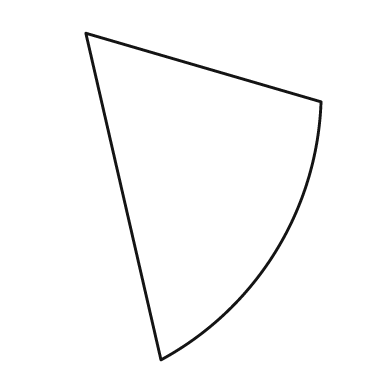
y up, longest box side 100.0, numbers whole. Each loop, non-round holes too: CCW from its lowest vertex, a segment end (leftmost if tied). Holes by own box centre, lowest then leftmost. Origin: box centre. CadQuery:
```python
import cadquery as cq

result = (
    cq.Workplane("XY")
    .moveTo(-13.0, -50.0)
    .threePointArc((22.0, -17.0), (36.0, 29.0))
    .lineTo(-36.0, 50.0)
    .close()
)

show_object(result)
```